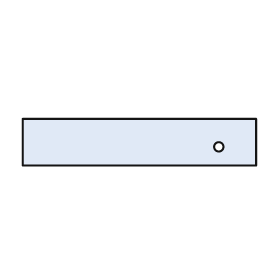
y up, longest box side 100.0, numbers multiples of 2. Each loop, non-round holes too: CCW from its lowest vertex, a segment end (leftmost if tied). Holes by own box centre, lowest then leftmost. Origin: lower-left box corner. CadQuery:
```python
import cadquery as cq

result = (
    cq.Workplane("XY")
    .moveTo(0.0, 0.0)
    .lineTo(100.0, 0.0)
    .lineTo(100.0, 20.0)
    .lineTo(0.0, 20.0)
    .close()
    .moveTo(84.0, 8.0)
    .circle(2.0)
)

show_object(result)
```